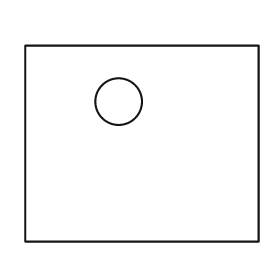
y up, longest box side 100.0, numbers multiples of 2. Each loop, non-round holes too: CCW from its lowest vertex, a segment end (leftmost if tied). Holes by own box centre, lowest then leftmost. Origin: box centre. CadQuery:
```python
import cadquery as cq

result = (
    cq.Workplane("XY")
    .moveTo(-50.0, -42.0)
    .lineTo(50.0, -42.0)
    .lineTo(50.0, 42.0)
    .lineTo(-50.0, 42.0)
    .close()
    .moveTo(-10.0, 18.0)
    .circle(10.0)
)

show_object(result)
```